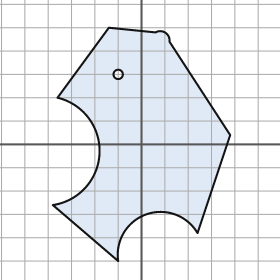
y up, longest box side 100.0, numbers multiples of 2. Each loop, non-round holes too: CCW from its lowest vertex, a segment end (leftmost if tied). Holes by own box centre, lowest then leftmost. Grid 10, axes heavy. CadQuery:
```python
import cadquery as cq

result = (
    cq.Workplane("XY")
    .moveTo(-10.0, -50.0)
    .threePointArc((2.0, -30.0), (24.0, -38.0))
    .lineTo(38.0, 4.0)
    .lineTo(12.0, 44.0)
    .threePointArc((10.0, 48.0), (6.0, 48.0))
    .lineTo(-14.0, 50.0)
    .lineTo(-36.0, 20.0)
    .threePointArc((-18.0, -4.0), (-38.0, -26.0))
    .close()
    .moveTo(-10.0, 30.0)
    .circle(2.0)
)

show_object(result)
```